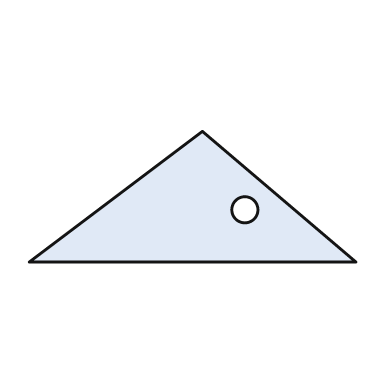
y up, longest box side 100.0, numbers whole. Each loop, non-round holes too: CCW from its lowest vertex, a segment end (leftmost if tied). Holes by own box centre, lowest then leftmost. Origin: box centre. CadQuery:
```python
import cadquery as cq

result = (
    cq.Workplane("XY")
    .moveTo(-50.0, -20.0)
    .lineTo(50.0, -20.0)
    .lineTo(3.0, 20.0)
    .close()
    .moveTo(16.0, -4.0)
    .circle(4.0)
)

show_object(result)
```